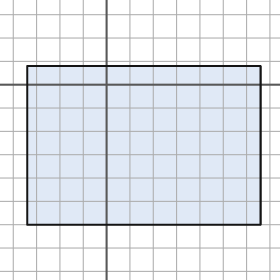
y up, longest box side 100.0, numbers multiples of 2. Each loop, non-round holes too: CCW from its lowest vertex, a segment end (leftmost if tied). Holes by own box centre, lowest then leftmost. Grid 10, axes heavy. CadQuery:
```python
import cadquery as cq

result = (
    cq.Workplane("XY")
    .moveTo(-34.0, -60.0)
    .lineTo(66.0, -60.0)
    .lineTo(66.0, 8.0)
    .lineTo(-34.0, 8.0)
    .close()
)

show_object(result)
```